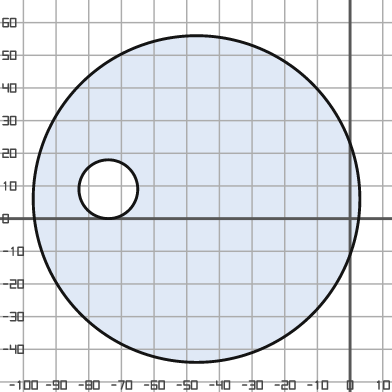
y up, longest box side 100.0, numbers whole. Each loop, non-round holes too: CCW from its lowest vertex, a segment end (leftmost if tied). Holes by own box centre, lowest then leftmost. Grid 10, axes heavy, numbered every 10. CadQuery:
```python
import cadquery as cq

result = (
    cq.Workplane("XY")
    .moveTo(-47.0, 6.0)
    .circle(50.0)
    .moveTo(-74.0, 9.0)
    .circle(9.0)
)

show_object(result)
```